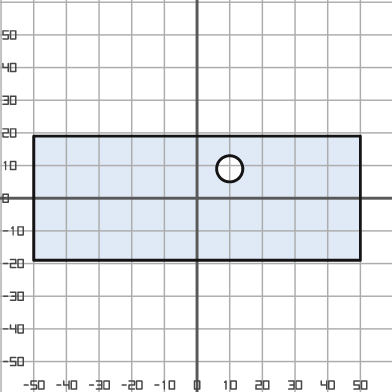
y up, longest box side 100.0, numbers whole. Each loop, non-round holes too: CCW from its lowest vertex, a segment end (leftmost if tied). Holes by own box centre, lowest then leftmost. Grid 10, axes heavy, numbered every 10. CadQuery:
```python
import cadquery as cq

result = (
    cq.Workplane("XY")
    .moveTo(-50.0, -19.0)
    .lineTo(50.0, -19.0)
    .lineTo(50.0, 19.0)
    .lineTo(-50.0, 19.0)
    .close()
    .moveTo(10.0, 9.0)
    .circle(4.0)
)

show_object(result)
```